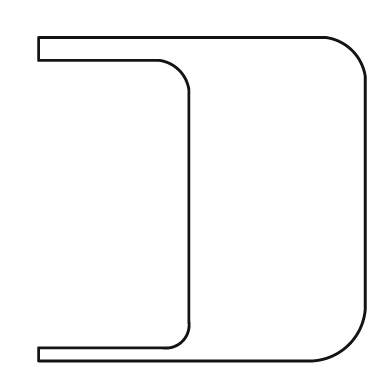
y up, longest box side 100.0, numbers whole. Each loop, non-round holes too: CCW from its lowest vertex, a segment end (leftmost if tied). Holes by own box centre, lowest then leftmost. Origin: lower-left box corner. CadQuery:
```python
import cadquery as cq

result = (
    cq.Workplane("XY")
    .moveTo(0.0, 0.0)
    .lineTo(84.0, 0.0)
    .threePointArc((95.0, 5.0), (100.0, 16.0))
    .lineTo(100.0, 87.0)
    .threePointArc((96.0, 95.0), (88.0, 99.0))
    .lineTo(0.0, 99.0)
    .lineTo(0.0, 92.0)
    .lineTo(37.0, 92.0)
    .threePointArc((43.0, 89.0), (46.0, 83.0))
    .lineTo(46.0, 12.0)
    .threePointArc((44.0, 6.0), (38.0, 4.0))
    .lineTo(0.0, 4.0)
    .close()
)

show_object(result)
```